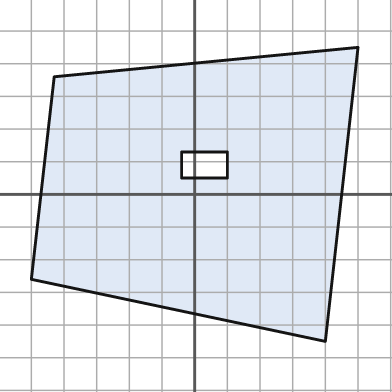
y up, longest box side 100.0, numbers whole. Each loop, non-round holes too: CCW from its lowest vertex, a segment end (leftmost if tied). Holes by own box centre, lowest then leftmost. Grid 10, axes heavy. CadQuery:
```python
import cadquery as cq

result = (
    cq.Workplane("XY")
    .moveTo(40.0, -45.0)
    .lineTo(50.0, 45.0)
    .lineTo(-43.0, 36.0)
    .lineTo(-50.0, -26.0)
    .close()
    .moveTo(-4.0, 5.0)
    .lineTo(10.0, 5.0)
    .lineTo(10.0, 13.0)
    .lineTo(-4.0, 13.0)
    .close()
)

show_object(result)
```